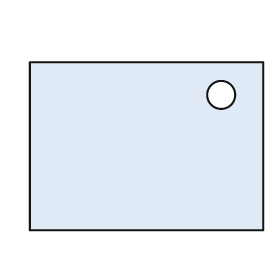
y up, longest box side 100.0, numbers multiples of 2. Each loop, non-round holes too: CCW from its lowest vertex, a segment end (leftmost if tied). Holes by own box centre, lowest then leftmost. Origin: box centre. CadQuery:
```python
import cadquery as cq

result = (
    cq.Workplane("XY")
    .moveTo(-50.0, -36.0)
    .lineTo(50.0, -36.0)
    .lineTo(50.0, 36.0)
    .lineTo(-50.0, 36.0)
    .close()
    .moveTo(32.0, 22.0)
    .circle(6.0)
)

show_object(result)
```